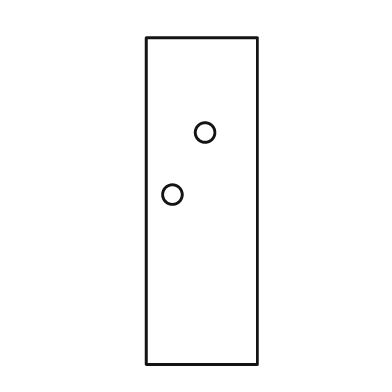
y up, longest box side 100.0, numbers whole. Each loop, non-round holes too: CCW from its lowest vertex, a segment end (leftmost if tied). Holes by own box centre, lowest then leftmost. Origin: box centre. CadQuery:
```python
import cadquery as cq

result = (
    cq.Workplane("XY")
    .moveTo(-17.0, -50.0)
    .lineTo(17.0, -50.0)
    .lineTo(17.0, 50.0)
    .lineTo(-17.0, 50.0)
    .close()
    .moveTo(-9.0, 2.0)
    .circle(3.0)
    .moveTo(1.0, 21.0)
    .circle(3.0)
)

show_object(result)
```